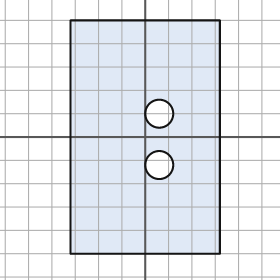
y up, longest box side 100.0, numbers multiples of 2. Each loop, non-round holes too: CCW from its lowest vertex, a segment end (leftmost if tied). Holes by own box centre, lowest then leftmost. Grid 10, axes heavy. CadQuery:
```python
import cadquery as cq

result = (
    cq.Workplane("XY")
    .moveTo(-32.0, -50.0)
    .lineTo(32.0, -50.0)
    .lineTo(32.0, 50.0)
    .lineTo(-32.0, 50.0)
    .close()
    .moveTo(6.0, -12.0)
    .circle(6.0)
    .moveTo(6.0, 10.0)
    .circle(6.0)
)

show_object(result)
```